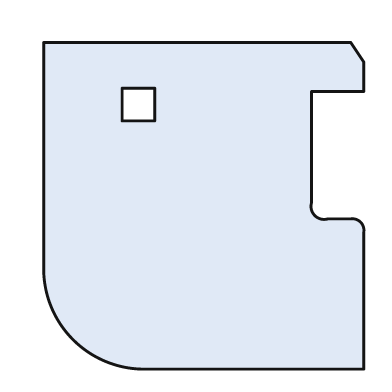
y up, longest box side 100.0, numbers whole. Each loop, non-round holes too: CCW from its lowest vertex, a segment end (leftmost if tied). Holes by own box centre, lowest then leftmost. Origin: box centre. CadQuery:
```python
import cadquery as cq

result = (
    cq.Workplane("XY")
    .moveTo(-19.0, -50.0)
    .lineTo(49.0, -50.0)
    .lineTo(49.0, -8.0)
    .threePointArc((48.0, -5.0), (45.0, -4.0))
    .lineTo(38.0, -4.0)
    .threePointArc((34.0, -3.0), (33.0, 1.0))
    .lineTo(33.0, 35.0)
    .lineTo(49.0, 35.0)
    .lineTo(49.0, 44.0)
    .lineTo(45.0, 50.0)
    .lineTo(-49.0, 50.0)
    .lineTo(-49.0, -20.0)
    .threePointArc((-40.0, -41.0), (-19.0, -50.0))
    .close()
    .moveTo(-25.0, 26.0)
    .lineTo(-15.0, 26.0)
    .lineTo(-15.0, 36.0)
    .lineTo(-25.0, 36.0)
    .close()
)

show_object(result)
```